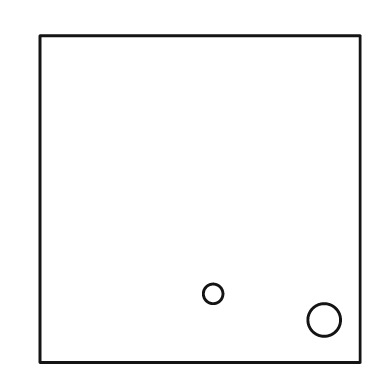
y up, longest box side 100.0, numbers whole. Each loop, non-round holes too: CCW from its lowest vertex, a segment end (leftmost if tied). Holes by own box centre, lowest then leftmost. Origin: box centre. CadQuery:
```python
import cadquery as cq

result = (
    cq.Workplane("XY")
    .moveTo(-49.0, -50.0)
    .lineTo(49.0, -50.0)
    .lineTo(49.0, 50.0)
    .lineTo(-49.0, 50.0)
    .close()
    .moveTo(38.0, -37.0)
    .circle(5.0)
    .moveTo(4.0, -29.0)
    .circle(3.0)
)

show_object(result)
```